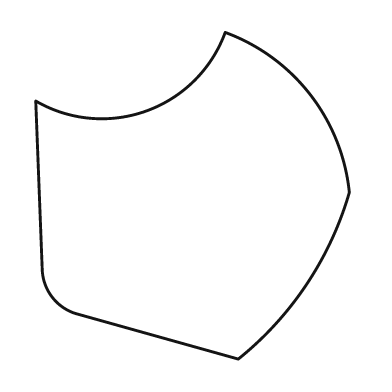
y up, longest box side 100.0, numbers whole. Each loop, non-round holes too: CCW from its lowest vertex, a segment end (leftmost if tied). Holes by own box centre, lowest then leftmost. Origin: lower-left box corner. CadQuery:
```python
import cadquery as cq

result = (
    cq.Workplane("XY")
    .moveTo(62.0, 0.0)
    .threePointArc((83.0, 23.0), (96.0, 51.0))
    .threePointArc((84.0, 81.0), (58.0, 100.0))
    .threePointArc((34.0, 76.0), (0.0, 79.0))
    .lineTo(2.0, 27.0)
    .threePointArc((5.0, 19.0), (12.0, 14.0))
    .close()
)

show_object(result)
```